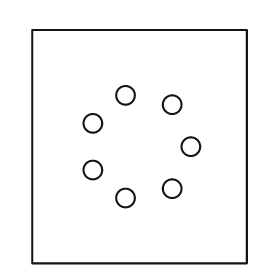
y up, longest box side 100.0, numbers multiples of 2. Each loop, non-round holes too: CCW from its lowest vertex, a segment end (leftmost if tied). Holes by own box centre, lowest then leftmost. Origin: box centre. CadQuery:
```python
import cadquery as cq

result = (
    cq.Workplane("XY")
    .moveTo(-46.0, -50.0)
    .lineTo(46.0, -50.0)
    .lineTo(46.0, 50.0)
    .lineTo(-46.0, 50.0)
    .close()
    .moveTo(-6.0, -22.0)
    .circle(4.0)
    .moveTo(14.0, -18.0)
    .circle(4.0)
    .moveTo(-20.0, -10.0)
    .circle(4.0)
    .moveTo(22.0, 0.0)
    .circle(4.0)
    .moveTo(-20.0, 10.0)
    .circle(4.0)
    .moveTo(14.0, 18.0)
    .circle(4.0)
    .moveTo(-6.0, 22.0)
    .circle(4.0)
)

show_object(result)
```